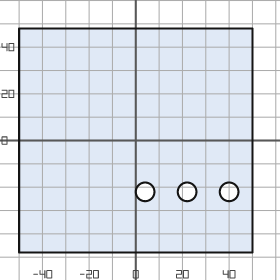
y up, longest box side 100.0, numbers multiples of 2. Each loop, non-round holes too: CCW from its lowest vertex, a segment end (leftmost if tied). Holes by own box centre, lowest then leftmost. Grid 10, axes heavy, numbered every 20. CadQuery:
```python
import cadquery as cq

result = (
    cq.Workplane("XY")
    .moveTo(-50.0, -48.0)
    .lineTo(50.0, -48.0)
    .lineTo(50.0, 48.0)
    .lineTo(-50.0, 48.0)
    .close()
    .moveTo(4.0, -22.0)
    .circle(4.0)
    .moveTo(22.0, -22.0)
    .circle(4.0)
    .moveTo(40.0, -22.0)
    .circle(4.0)
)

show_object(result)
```